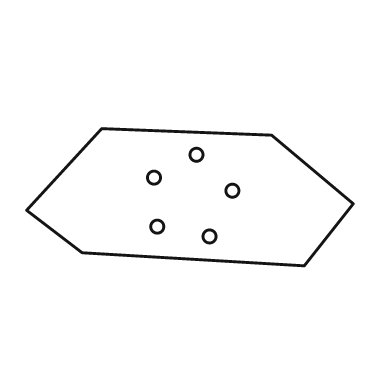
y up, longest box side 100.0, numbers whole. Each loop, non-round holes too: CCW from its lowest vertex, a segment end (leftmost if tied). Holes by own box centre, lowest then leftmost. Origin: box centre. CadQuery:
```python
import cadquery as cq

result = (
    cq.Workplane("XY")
    .moveTo(35.0, -21.0)
    .lineTo(50.0, -2.0)
    .lineTo(25.0, 19.0)
    .lineTo(-27.0, 21.0)
    .lineTo(-50.0, -4.0)
    .lineTo(-33.0, -17.0)
    .close()
    .moveTo(6.0, -12.0)
    .circle(2.0)
    .moveTo(-10.0, -9.0)
    .circle(2.0)
    .moveTo(13.0, 2.0)
    .circle(2.0)
    .moveTo(-11.0, 6.0)
    .circle(2.0)
    .moveTo(2.0, 13.0)
    .circle(2.0)
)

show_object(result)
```